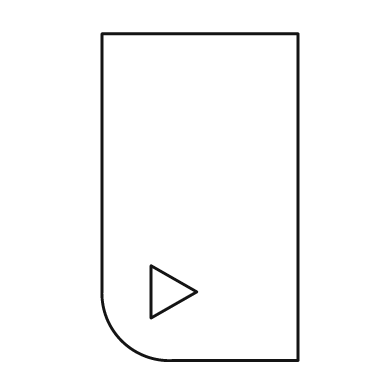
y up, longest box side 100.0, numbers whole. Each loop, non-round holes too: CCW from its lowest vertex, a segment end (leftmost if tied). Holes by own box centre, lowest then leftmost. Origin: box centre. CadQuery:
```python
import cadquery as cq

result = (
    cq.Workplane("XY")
    .moveTo(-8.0, -50.0)
    .lineTo(30.0, -50.0)
    .lineTo(30.0, 50.0)
    .lineTo(-30.0, 50.0)
    .lineTo(-30.0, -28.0)
    .threePointArc((-24.0, -44.0), (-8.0, -50.0))
    .close()
    .moveTo(-15.0, -37.0)
    .lineTo(-1.0, -29.0)
    .lineTo(-15.0, -21.0)
    .close()
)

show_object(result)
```